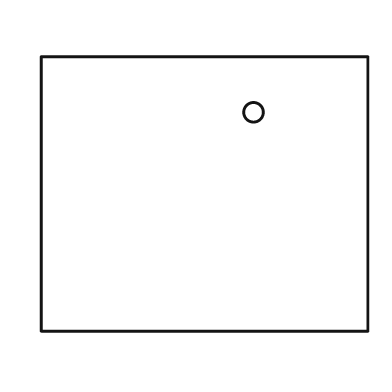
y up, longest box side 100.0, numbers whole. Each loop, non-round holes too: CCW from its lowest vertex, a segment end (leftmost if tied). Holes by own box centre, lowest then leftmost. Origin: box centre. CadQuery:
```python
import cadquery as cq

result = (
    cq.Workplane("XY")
    .moveTo(-50.0, -42.0)
    .lineTo(50.0, -42.0)
    .lineTo(50.0, 42.0)
    .lineTo(-50.0, 42.0)
    .close()
    .moveTo(15.0, 25.0)
    .circle(3.0)
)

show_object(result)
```